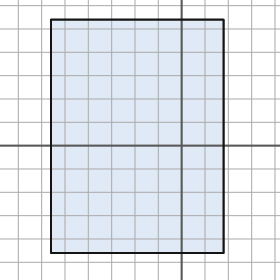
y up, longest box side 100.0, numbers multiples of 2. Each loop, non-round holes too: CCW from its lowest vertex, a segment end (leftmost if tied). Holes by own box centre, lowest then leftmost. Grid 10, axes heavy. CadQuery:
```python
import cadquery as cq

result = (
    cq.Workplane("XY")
    .moveTo(-56.0, -46.0)
    .lineTo(18.0, -46.0)
    .lineTo(18.0, 54.0)
    .lineTo(-56.0, 54.0)
    .close()
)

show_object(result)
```